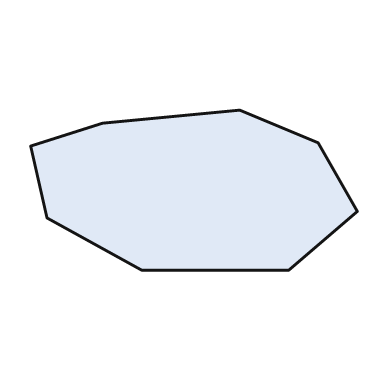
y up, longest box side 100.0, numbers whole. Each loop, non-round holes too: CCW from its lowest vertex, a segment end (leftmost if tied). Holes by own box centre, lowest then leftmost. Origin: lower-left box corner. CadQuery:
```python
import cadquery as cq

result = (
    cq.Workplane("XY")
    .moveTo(34.0, 0.0)
    .lineTo(79.0, 0.0)
    .lineTo(100.0, 18.0)
    .lineTo(88.0, 39.0)
    .lineTo(64.0, 49.0)
    .lineTo(22.0, 45.0)
    .lineTo(0.0, 38.0)
    .lineTo(5.0, 16.0)
    .close()
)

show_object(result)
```